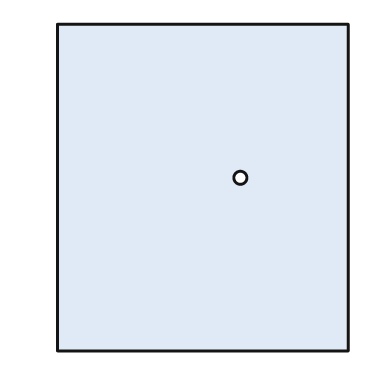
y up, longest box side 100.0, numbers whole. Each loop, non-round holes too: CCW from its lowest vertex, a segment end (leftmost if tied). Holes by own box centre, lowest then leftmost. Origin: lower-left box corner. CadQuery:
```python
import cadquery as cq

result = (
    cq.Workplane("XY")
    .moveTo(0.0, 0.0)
    .lineTo(89.0, 0.0)
    .lineTo(89.0, 100.0)
    .lineTo(0.0, 100.0)
    .close()
    .moveTo(56.0, 53.0)
    .circle(2.0)
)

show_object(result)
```